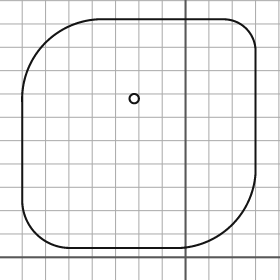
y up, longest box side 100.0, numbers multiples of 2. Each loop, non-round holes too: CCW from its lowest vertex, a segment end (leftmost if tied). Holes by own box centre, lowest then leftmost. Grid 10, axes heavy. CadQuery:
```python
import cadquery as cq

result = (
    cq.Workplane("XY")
    .moveTo(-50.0, 4.0)
    .lineTo(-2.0, 4.0)
    .threePointArc((20.0, 14.0), (30.0, 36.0))
    .lineTo(30.0, 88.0)
    .threePointArc((26.0, 98.0), (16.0, 102.0))
    .lineTo(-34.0, 102.0)
    .threePointArc((-60.0, 92.0), (-70.0, 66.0))
    .lineTo(-70.0, 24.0)
    .threePointArc((-64.0, 10.0), (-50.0, 4.0))
    .close()
    .moveTo(-22.0, 68.0)
    .circle(2.0)
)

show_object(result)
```